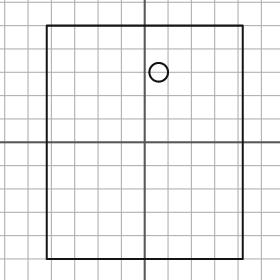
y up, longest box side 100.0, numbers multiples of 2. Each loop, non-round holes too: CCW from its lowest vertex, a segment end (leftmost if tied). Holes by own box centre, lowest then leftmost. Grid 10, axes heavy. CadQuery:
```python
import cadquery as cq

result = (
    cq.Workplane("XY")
    .moveTo(-42.0, -50.0)
    .lineTo(42.0, -50.0)
    .lineTo(42.0, 50.0)
    .lineTo(-42.0, 50.0)
    .close()
    .moveTo(6.0, 30.0)
    .circle(4.0)
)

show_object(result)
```